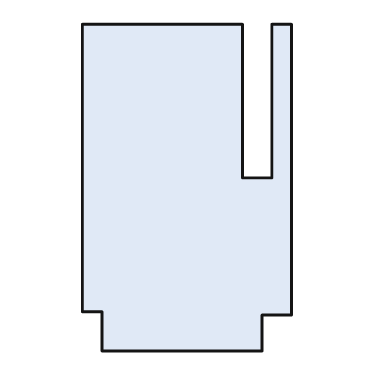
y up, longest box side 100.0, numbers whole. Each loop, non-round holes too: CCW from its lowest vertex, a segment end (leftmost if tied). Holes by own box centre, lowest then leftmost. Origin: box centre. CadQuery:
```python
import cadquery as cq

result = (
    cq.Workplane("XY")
    .moveTo(-26.0, -50.0)
    .lineTo(23.0, -50.0)
    .lineTo(23.0, -39.0)
    .lineTo(32.0, -39.0)
    .lineTo(32.0, 50.0)
    .lineTo(26.0, 50.0)
    .lineTo(26.0, 3.0)
    .lineTo(17.0, 3.0)
    .lineTo(17.0, 50.0)
    .lineTo(-32.0, 50.0)
    .lineTo(-32.0, -38.0)
    .lineTo(-26.0, -38.0)
    .close()
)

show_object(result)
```